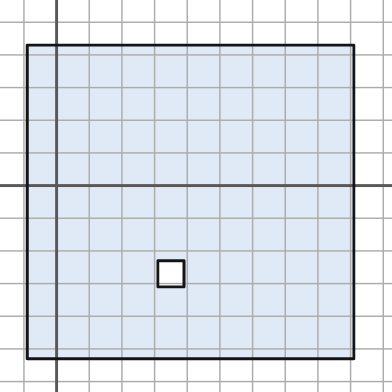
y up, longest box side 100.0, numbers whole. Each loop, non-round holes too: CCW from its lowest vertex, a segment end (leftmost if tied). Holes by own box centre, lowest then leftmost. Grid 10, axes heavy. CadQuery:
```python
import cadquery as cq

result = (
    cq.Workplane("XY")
    .moveTo(-9.0, -53.0)
    .lineTo(91.0, -53.0)
    .lineTo(91.0, 43.0)
    .lineTo(-9.0, 43.0)
    .close()
    .moveTo(31.0, -31.0)
    .lineTo(39.0, -31.0)
    .lineTo(39.0, -23.0)
    .lineTo(31.0, -23.0)
    .close()
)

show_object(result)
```